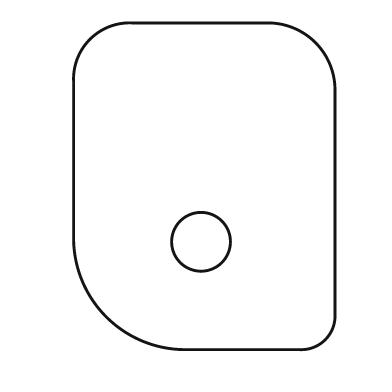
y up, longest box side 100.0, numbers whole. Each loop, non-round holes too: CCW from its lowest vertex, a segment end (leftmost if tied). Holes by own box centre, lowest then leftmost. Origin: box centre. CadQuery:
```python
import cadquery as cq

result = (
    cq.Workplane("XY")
    .moveTo(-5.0, -50.0)
    .lineTo(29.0, -50.0)
    .threePointArc((37.0, -47.0), (40.0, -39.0))
    .lineTo(40.0, 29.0)
    .threePointArc((34.0, 44.0), (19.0, 50.0))
    .lineTo(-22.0, 50.0)
    .threePointArc((-35.0, 45.0), (-40.0, 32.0))
    .lineTo(-40.0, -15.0)
    .threePointArc((-30.0, -40.0), (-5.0, -50.0))
    .close()
    .moveTo(-1.0, -17.0)
    .circle(9.0)
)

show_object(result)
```